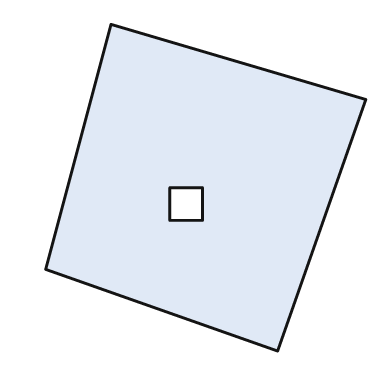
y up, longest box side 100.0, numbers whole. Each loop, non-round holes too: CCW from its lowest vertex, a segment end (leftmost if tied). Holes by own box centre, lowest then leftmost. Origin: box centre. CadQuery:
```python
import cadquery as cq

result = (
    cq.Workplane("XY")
    .moveTo(22.0, -50.0)
    .lineTo(49.0, 27.0)
    .lineTo(-29.0, 50.0)
    .lineTo(-49.0, -25.0)
    .close()
    .moveTo(-11.0, -10.0)
    .lineTo(-1.0, -10.0)
    .lineTo(-1.0, 0.0)
    .lineTo(-11.0, 0.0)
    .close()
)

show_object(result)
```